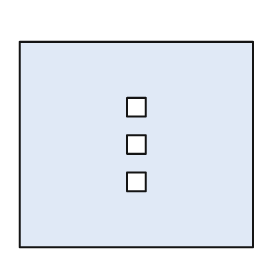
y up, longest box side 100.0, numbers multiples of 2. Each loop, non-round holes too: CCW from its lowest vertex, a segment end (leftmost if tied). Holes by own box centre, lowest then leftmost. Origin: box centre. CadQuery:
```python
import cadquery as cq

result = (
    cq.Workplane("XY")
    .moveTo(-50.0, -44.0)
    .lineTo(50.0, -44.0)
    .lineTo(50.0, 44.0)
    .lineTo(-50.0, 44.0)
    .close()
    .moveTo(-4.0, -20.0)
    .lineTo(4.0, -20.0)
    .lineTo(4.0, -12.0)
    .lineTo(-4.0, -12.0)
    .close()
    .moveTo(-4.0, -4.0)
    .lineTo(4.0, -4.0)
    .lineTo(4.0, 4.0)
    .lineTo(-4.0, 4.0)
    .close()
    .moveTo(-4.0, 12.0)
    .lineTo(4.0, 12.0)
    .lineTo(4.0, 20.0)
    .lineTo(-4.0, 20.0)
    .close()
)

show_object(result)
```